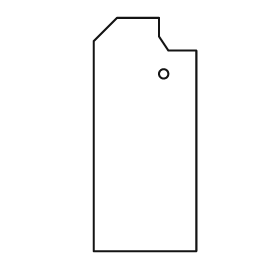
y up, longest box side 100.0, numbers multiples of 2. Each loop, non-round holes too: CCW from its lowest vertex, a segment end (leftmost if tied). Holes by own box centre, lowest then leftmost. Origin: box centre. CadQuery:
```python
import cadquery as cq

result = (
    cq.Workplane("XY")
    .moveTo(-22.0, -50.0)
    .lineTo(22.0, -50.0)
    .lineTo(22.0, 36.0)
    .lineTo(10.0, 36.0)
    .lineTo(6.0, 42.0)
    .lineTo(6.0, 50.0)
    .lineTo(-12.0, 50.0)
    .lineTo(-22.0, 40.0)
    .close()
    .moveTo(8.0, 26.0)
    .circle(2.0)
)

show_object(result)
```